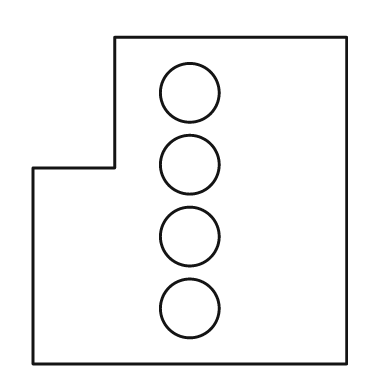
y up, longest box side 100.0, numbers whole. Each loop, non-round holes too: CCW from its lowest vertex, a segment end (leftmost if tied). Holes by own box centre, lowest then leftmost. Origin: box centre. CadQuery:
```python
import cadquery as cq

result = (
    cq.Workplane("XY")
    .moveTo(-48.0, -50.0)
    .lineTo(48.0, -50.0)
    .lineTo(48.0, 50.0)
    .lineTo(-23.0, 50.0)
    .lineTo(-23.0, 10.0)
    .lineTo(-48.0, 10.0)
    .close()
    .moveTo(0.0, -33.0)
    .circle(9.0)
    .moveTo(0.0, -11.0)
    .circle(9.0)
    .moveTo(0.0, 11.0)
    .circle(9.0)
    .moveTo(0.0, 33.0)
    .circle(9.0)
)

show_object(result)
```